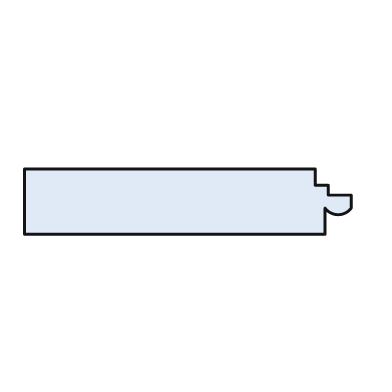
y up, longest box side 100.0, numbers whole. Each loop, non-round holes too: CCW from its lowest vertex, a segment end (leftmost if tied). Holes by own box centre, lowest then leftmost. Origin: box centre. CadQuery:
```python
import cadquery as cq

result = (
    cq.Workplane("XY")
    .moveTo(-50.0, -10.0)
    .lineTo(42.0, -10.0)
    .lineTo(42.0, -2.0)
    .threePointArc((46.0, -4.0), (50.0, -2.0))
    .lineTo(50.0, 2.0)
    .lineTo(43.0, 2.0)
    .lineTo(43.0, 5.0)
    .lineTo(39.0, 5.0)
    .lineTo(39.0, 10.0)
    .lineTo(-50.0, 10.0)
    .close()
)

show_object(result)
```